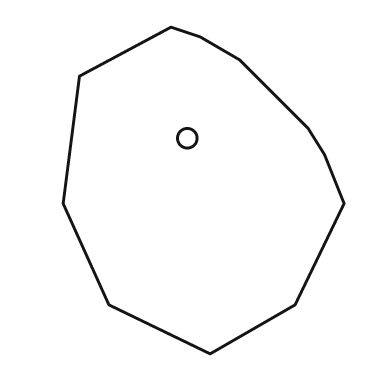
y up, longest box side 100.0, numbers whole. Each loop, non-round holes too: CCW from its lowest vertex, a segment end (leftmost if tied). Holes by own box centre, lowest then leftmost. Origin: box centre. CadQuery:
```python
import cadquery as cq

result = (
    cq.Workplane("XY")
    .moveTo(2.0, -50.0)
    .lineTo(28.0, -35.0)
    .lineTo(43.0, -4.0)
    .lineTo(37.0, 11.0)
    .lineTo(32.0, 19.0)
    .lineTo(11.0, 40.0)
    .lineTo(-1.0, 47.0)
    .lineTo(-10.0, 50.0)
    .lineTo(-38.0, 35.0)
    .lineTo(-43.0, -4.0)
    .lineTo(-29.0, -35.0)
    .close()
    .moveTo(-5.0, 16.0)
    .circle(3.0)
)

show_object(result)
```